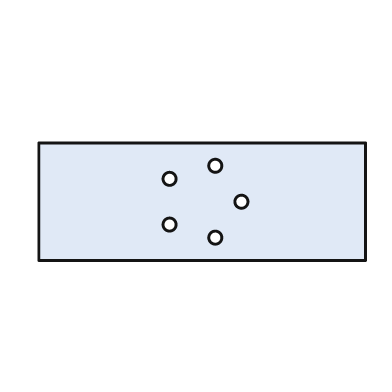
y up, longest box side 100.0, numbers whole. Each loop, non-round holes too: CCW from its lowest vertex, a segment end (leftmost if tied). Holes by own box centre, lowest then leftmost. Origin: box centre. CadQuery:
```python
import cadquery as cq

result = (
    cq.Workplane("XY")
    .moveTo(-50.0, -18.0)
    .lineTo(50.0, -18.0)
    .lineTo(50.0, 18.0)
    .lineTo(-50.0, 18.0)
    .close()
    .moveTo(4.0, -11.0)
    .circle(2.0)
    .moveTo(-10.0, -7.0)
    .circle(2.0)
    .moveTo(12.0, 0.0)
    .circle(2.0)
    .moveTo(-10.0, 7.0)
    .circle(2.0)
    .moveTo(4.0, 11.0)
    .circle(2.0)
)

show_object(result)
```